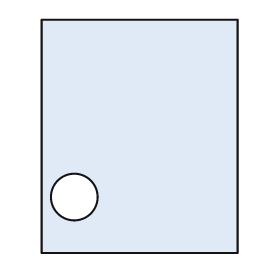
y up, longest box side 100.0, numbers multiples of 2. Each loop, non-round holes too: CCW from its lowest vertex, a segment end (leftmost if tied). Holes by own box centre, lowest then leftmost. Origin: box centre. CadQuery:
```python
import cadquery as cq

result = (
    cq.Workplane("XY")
    .moveTo(-42.0, -50.0)
    .lineTo(42.0, -50.0)
    .lineTo(42.0, 50.0)
    .lineTo(-42.0, 50.0)
    .close()
    .moveTo(-28.0, -26.0)
    .circle(10.0)
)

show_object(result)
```